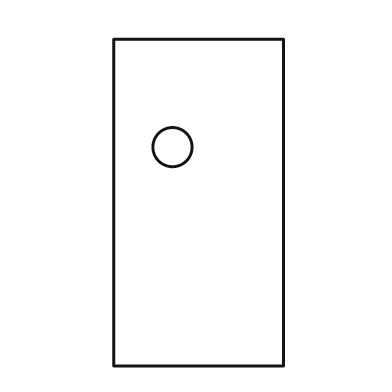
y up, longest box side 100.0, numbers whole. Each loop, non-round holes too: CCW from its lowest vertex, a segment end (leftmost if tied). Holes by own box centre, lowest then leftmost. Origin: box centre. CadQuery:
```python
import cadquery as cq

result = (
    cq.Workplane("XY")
    .moveTo(-26.0, -50.0)
    .lineTo(26.0, -50.0)
    .lineTo(26.0, 50.0)
    .lineTo(-26.0, 50.0)
    .close()
    .moveTo(-8.0, 17.0)
    .circle(6.0)
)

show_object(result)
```